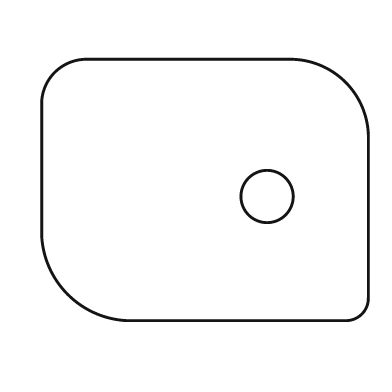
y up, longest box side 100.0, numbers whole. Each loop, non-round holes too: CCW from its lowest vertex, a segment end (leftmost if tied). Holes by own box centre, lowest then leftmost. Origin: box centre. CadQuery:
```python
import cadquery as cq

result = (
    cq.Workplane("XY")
    .moveTo(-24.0, -40.0)
    .lineTo(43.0, -40.0)
    .threePointArc((48.0, -38.0), (50.0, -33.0))
    .lineTo(50.0, 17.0)
    .threePointArc((43.0, 33.0), (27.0, 40.0))
    .lineTo(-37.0, 40.0)
    .threePointArc((-46.0, 36.0), (-50.0, 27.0))
    .lineTo(-50.0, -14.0)
    .threePointArc((-42.0, -32.0), (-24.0, -40.0))
    .close()
    .moveTo(19.0, -2.0)
    .circle(8.0)
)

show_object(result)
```